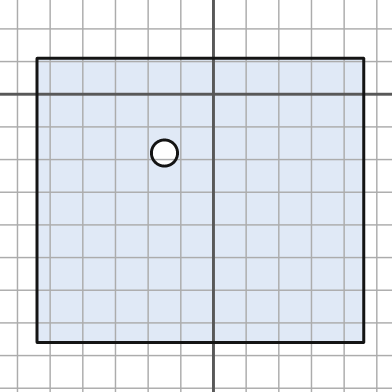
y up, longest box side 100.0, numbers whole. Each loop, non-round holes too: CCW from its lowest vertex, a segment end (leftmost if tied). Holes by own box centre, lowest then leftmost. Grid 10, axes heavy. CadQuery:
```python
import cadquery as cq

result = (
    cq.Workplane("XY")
    .moveTo(-54.0, -76.0)
    .lineTo(46.0, -76.0)
    .lineTo(46.0, 11.0)
    .lineTo(-54.0, 11.0)
    .close()
    .moveTo(-15.0, -18.0)
    .circle(4.0)
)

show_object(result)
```